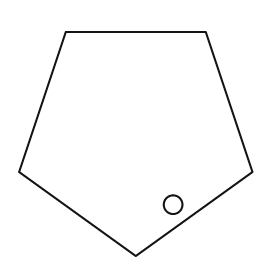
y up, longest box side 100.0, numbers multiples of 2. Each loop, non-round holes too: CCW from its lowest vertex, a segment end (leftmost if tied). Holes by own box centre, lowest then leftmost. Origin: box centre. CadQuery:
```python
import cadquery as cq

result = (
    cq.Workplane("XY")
    .moveTo(0.0, -48.0)
    .lineTo(50.0, -12.0)
    .lineTo(30.0, 48.0)
    .lineTo(-30.0, 48.0)
    .lineTo(-50.0, -12.0)
    .close()
    .moveTo(16.0, -26.0)
    .circle(4.0)
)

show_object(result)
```